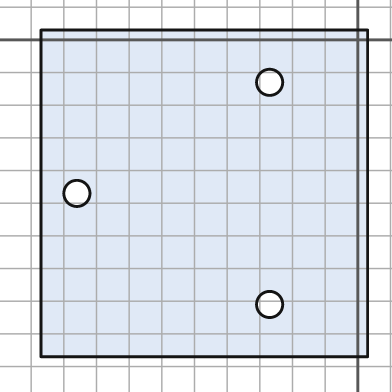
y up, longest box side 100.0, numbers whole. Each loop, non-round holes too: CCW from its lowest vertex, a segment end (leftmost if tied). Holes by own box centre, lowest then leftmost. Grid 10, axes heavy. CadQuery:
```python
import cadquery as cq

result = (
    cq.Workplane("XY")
    .moveTo(-97.0, -97.0)
    .lineTo(3.0, -97.0)
    .lineTo(3.0, 3.0)
    .lineTo(-97.0, 3.0)
    .close()
    .moveTo(-27.0, -81.0)
    .circle(4.0)
    .moveTo(-86.0, -47.0)
    .circle(4.0)
    .moveTo(-27.0, -13.0)
    .circle(4.0)
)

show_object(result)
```